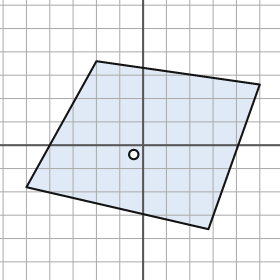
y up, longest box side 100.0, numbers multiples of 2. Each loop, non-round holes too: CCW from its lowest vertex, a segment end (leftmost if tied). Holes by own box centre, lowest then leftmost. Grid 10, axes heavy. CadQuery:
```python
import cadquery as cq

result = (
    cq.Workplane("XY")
    .moveTo(28.0, -36.0)
    .lineTo(50.0, 26.0)
    .lineTo(-20.0, 36.0)
    .lineTo(-50.0, -18.0)
    .close()
    .moveTo(-4.0, -4.0)
    .circle(2.0)
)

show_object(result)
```